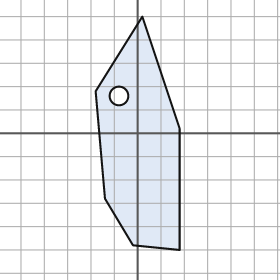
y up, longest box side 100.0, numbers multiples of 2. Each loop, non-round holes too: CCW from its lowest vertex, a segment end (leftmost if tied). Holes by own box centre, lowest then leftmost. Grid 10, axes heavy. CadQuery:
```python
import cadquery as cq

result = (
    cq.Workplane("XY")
    .moveTo(18.0, -50.0)
    .lineTo(18.0, 2.0)
    .lineTo(2.0, 50.0)
    .lineTo(-18.0, 18.0)
    .lineTo(-14.0, -28.0)
    .lineTo(-2.0, -48.0)
    .close()
    .moveTo(-8.0, 16.0)
    .circle(4.0)
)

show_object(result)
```